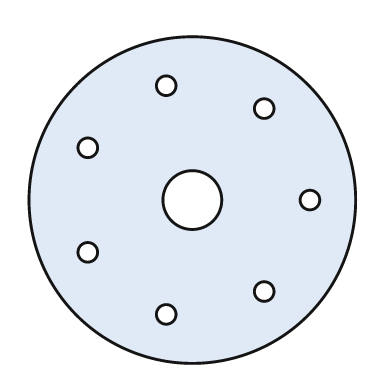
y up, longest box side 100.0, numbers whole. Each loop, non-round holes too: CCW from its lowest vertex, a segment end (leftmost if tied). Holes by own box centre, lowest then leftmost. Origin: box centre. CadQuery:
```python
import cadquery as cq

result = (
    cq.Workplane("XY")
    .moveTo(0.0, 0.0)
    .circle(50.0)
    .moveTo(-8.0, -35.0)
    .circle(3.0)
    .moveTo(22.0, -28.0)
    .circle(3.0)
    .moveTo(-32.0, -16.0)
    .circle(3.0)
    .moveTo(0.0, 0.0)
    .circle(9.0)
    .moveTo(36.0, 0.0)
    .circle(3.0)
    .moveTo(-32.0, 16.0)
    .circle(3.0)
    .moveTo(22.0, 28.0)
    .circle(3.0)
    .moveTo(-8.0, 35.0)
    .circle(3.0)
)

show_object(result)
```